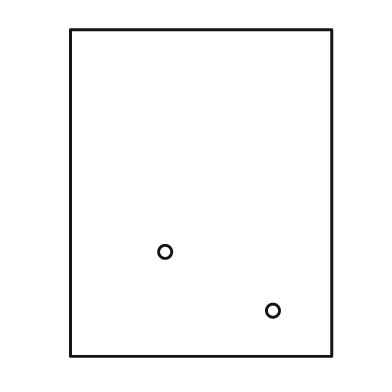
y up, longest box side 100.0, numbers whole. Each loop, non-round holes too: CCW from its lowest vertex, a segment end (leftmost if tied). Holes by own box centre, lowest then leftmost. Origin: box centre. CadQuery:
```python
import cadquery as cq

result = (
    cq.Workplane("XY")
    .moveTo(-40.0, -50.0)
    .lineTo(40.0, -50.0)
    .lineTo(40.0, 50.0)
    .lineTo(-40.0, 50.0)
    .close()
    .moveTo(22.0, -36.0)
    .circle(2.0)
    .moveTo(-11.0, -18.0)
    .circle(2.0)
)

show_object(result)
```